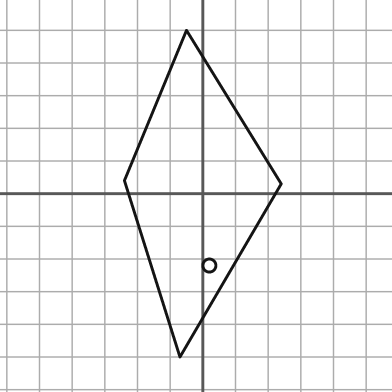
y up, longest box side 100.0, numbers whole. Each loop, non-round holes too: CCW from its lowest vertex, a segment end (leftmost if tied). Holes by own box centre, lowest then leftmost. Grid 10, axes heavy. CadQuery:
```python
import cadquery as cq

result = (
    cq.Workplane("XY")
    .moveTo(-7.0, -50.0)
    .lineTo(24.0, 3.0)
    .lineTo(-5.0, 50.0)
    .lineTo(-24.0, 4.0)
    .close()
    .moveTo(2.0, -22.0)
    .circle(2.0)
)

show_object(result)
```